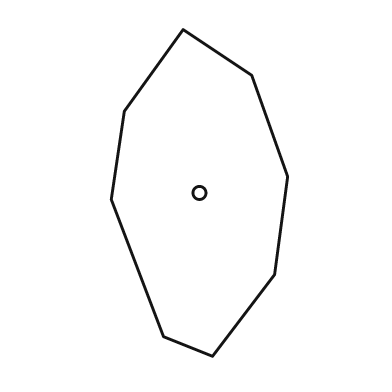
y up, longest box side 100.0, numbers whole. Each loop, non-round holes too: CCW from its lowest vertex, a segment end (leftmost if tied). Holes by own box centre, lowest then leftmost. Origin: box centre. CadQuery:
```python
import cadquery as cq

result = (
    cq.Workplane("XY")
    .moveTo(4.0, -50.0)
    .lineTo(23.0, -25.0)
    .lineTo(27.0, 5.0)
    .lineTo(16.0, 36.0)
    .lineTo(-5.0, 50.0)
    .lineTo(-23.0, 25.0)
    .lineTo(-27.0, -2.0)
    .lineTo(-11.0, -44.0)
    .close()
    .moveTo(0.0, 0.0)
    .circle(2.0)
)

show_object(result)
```